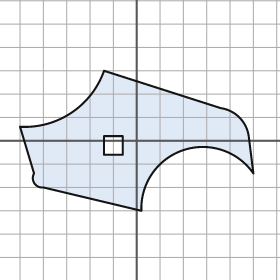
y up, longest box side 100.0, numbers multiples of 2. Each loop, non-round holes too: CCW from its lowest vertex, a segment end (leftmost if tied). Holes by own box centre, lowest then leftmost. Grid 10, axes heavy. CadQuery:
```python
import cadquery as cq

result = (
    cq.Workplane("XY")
    .moveTo(2.0, -30.0)
    .threePointArc((20.0, -4.0), (50.0, -14.0))
    .lineTo(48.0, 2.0)
    .threePointArc((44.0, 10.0), (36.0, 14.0))
    .lineTo(-14.0, 30.0)
    .threePointArc((-28.0, 12.0), (-50.0, 6.0))
    .lineTo(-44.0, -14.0)
    .threePointArc((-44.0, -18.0), (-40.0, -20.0))
    .close()
    .moveTo(-14.0, -6.0)
    .lineTo(-6.0, -6.0)
    .lineTo(-6.0, 2.0)
    .lineTo(-14.0, 2.0)
    .close()
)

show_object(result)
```